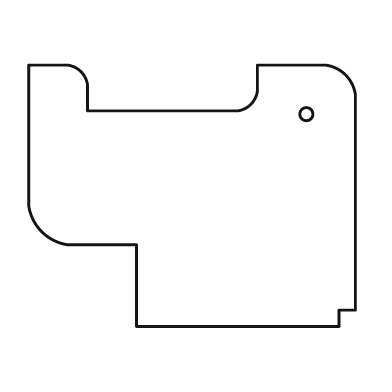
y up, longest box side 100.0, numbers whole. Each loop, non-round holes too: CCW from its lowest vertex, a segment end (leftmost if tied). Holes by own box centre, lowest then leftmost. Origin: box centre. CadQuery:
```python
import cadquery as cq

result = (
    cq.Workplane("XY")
    .moveTo(-17.0, -40.0)
    .lineTo(45.0, -40.0)
    .lineTo(45.0, -35.0)
    .lineTo(50.0, -35.0)
    .lineTo(50.0, 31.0)
    .threePointArc((47.0, 37.0), (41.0, 40.0))
    .lineTo(20.0, 40.0)
    .lineTo(20.0, 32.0)
    .threePointArc((18.0, 28.0), (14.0, 26.0))
    .lineTo(-32.0, 26.0)
    .lineTo(-32.0, 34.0)
    .threePointArc((-34.0, 38.0), (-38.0, 40.0))
    .lineTo(-50.0, 40.0)
    .lineTo(-50.0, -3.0)
    .threePointArc((-46.0, -11.0), (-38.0, -15.0))
    .lineTo(-17.0, -15.0)
    .close()
    .moveTo(35.0, 25.0)
    .circle(2.0)
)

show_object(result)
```